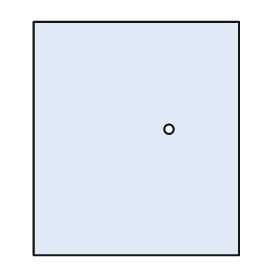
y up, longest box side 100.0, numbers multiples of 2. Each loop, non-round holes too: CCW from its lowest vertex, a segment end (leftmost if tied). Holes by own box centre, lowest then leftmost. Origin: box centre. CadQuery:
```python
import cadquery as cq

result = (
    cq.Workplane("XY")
    .moveTo(-44.0, -50.0)
    .lineTo(44.0, -50.0)
    .lineTo(44.0, 50.0)
    .lineTo(-44.0, 50.0)
    .close()
    .moveTo(14.0, 4.0)
    .circle(2.0)
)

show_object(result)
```